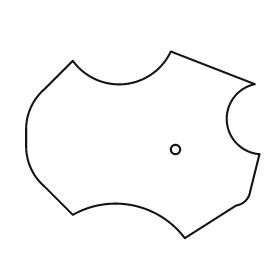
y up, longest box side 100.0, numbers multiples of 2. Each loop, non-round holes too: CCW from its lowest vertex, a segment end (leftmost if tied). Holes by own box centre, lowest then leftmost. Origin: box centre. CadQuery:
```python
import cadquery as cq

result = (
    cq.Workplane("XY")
    .moveTo(18.0, -40.0)
    .lineTo(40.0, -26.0)
    .threePointArc((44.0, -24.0), (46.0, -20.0))
    .lineTo(50.0, -4.0)
    .threePointArc((36.0, 10.0), (48.0, 26.0))
    .lineTo(12.0, 40.0)
    .threePointArc((-8.0, 26.0), (-30.0, 36.0))
    .lineTo(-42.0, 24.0)
    .threePointArc((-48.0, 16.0), (-50.0, 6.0))
    .lineTo(-50.0, 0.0)
    .threePointArc((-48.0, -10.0), (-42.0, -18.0))
    .lineTo(-30.0, -30.0)
    .threePointArc((-4.0, -26.0), (18.0, -40.0))
    .close()
    .moveTo(14.0, -2.0)
    .circle(2.0)
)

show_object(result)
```